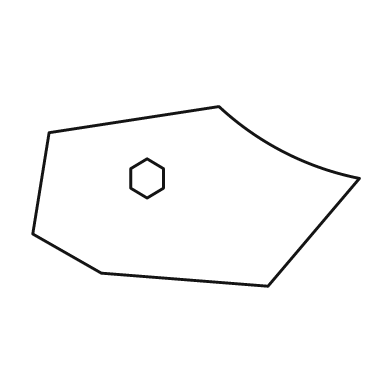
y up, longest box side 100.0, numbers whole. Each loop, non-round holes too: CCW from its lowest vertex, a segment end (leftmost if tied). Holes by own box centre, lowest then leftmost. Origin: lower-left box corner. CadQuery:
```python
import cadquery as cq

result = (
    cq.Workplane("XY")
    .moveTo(72.0, 0.0)
    .lineTo(100.0, 33.0)
    .threePointArc((77.0, 41.0), (57.0, 55.0))
    .lineTo(5.0, 47.0)
    .lineTo(0.0, 16.0)
    .lineTo(21.0, 4.0)
    .close()
    .moveTo(35.0, 27.0)
    .lineTo(40.0, 30.0)
    .lineTo(40.0, 36.0)
    .lineTo(35.0, 39.0)
    .lineTo(30.0, 36.0)
    .lineTo(30.0, 30.0)
    .close()
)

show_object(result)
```